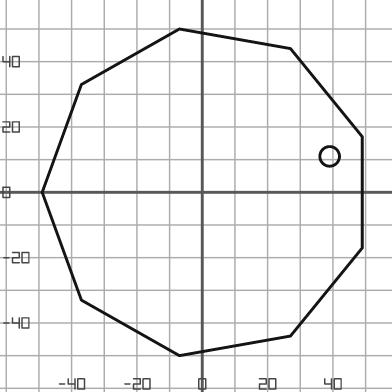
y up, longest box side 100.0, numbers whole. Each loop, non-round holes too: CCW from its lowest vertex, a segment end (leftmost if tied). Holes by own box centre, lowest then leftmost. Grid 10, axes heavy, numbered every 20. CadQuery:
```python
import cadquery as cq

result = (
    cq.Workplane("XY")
    .moveTo(-7.0, -50.0)
    .lineTo(27.0, -44.0)
    .lineTo(49.0, -17.0)
    .lineTo(49.0, 17.0)
    .lineTo(27.0, 44.0)
    .lineTo(-7.0, 50.0)
    .lineTo(-37.0, 33.0)
    .lineTo(-49.0, 0.0)
    .lineTo(-37.0, -33.0)
    .close()
    .moveTo(39.0, 11.0)
    .circle(3.0)
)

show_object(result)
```